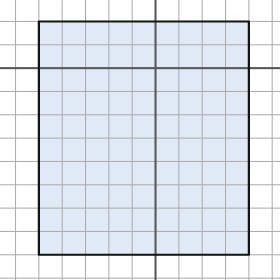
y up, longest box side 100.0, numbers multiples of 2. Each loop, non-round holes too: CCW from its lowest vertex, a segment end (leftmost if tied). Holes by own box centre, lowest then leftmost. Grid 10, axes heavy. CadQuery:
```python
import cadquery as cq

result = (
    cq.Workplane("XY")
    .moveTo(-50.0, -80.0)
    .lineTo(40.0, -80.0)
    .lineTo(40.0, 20.0)
    .lineTo(-50.0, 20.0)
    .close()
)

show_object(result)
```